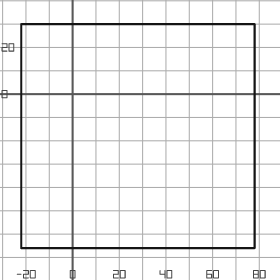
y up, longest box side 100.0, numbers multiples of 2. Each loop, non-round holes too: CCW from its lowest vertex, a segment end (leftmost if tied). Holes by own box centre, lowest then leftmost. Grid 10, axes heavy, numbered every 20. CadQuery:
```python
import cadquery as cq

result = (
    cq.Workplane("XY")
    .moveTo(-22.0, -66.0)
    .lineTo(78.0, -66.0)
    .lineTo(78.0, 30.0)
    .lineTo(-22.0, 30.0)
    .close()
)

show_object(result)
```